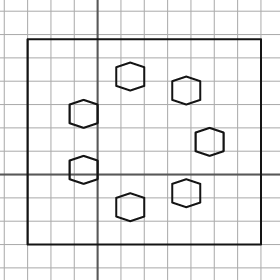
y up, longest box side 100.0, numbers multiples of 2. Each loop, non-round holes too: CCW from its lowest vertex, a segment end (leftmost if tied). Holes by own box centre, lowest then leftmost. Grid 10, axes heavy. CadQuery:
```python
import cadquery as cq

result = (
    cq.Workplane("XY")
    .moveTo(-30.0, -30.0)
    .lineTo(70.0, -30.0)
    .lineTo(70.0, 58.0)
    .lineTo(-30.0, 58.0)
    .close()
    .moveTo(14.0, -20.0)
    .lineTo(20.0, -18.0)
    .lineTo(20.0, -10.0)
    .lineTo(14.0, -8.0)
    .lineTo(8.0, -10.0)
    .lineTo(8.0, -18.0)
    .close()
    .moveTo(38.0, -14.0)
    .lineTo(44.0, -12.0)
    .lineTo(44.0, -4.0)
    .lineTo(38.0, -2.0)
    .lineTo(32.0, -4.0)
    .lineTo(32.0, -12.0)
    .close()
    .moveTo(-6.0, -4.0)
    .lineTo(0.0, -2.0)
    .lineTo(0.0, 6.0)
    .lineTo(-6.0, 8.0)
    .lineTo(-12.0, 6.0)
    .lineTo(-12.0, -2.0)
    .close()
    .moveTo(48.0, 8.0)
    .lineTo(54.0, 10.0)
    .lineTo(54.0, 18.0)
    .lineTo(48.0, 20.0)
    .lineTo(42.0, 18.0)
    .lineTo(42.0, 10.0)
    .close()
    .moveTo(-6.0, 20.0)
    .lineTo(0.0, 22.0)
    .lineTo(0.0, 30.0)
    .lineTo(-6.0, 32.0)
    .lineTo(-12.0, 30.0)
    .lineTo(-12.0, 22.0)
    .close()
    .moveTo(38.0, 30.0)
    .lineTo(44.0, 32.0)
    .lineTo(44.0, 40.0)
    .lineTo(38.0, 42.0)
    .lineTo(32.0, 40.0)
    .lineTo(32.0, 32.0)
    .close()
    .moveTo(14.0, 36.0)
    .lineTo(20.0, 38.0)
    .lineTo(20.0, 46.0)
    .lineTo(14.0, 48.0)
    .lineTo(8.0, 46.0)
    .lineTo(8.0, 38.0)
    .close()
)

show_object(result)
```